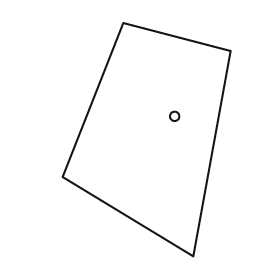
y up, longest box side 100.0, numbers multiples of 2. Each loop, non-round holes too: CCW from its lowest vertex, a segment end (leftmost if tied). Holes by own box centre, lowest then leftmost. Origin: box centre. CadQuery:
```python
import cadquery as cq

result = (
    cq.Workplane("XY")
    .moveTo(20.0, -50.0)
    .lineTo(36.0, 38.0)
    .lineTo(-10.0, 50.0)
    .lineTo(-36.0, -16.0)
    .close()
    .moveTo(12.0, 10.0)
    .circle(2.0)
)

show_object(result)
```